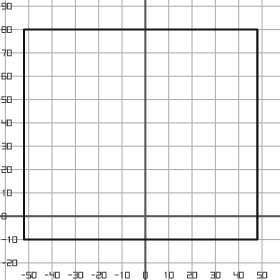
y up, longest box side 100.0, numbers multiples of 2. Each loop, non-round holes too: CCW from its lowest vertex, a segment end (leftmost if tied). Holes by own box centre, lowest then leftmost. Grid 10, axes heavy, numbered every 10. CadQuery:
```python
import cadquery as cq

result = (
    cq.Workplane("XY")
    .moveTo(-52.0, -10.0)
    .lineTo(48.0, -10.0)
    .lineTo(48.0, 80.0)
    .lineTo(-52.0, 80.0)
    .close()
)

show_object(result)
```